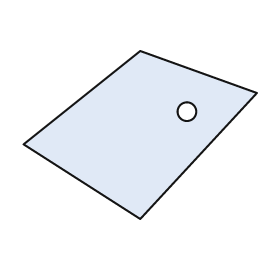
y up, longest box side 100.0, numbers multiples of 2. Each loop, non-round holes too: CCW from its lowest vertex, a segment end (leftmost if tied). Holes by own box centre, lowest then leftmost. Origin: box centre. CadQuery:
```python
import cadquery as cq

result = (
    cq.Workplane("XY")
    .moveTo(0.0, -36.0)
    .lineTo(50.0, 18.0)
    .lineTo(0.0, 36.0)
    .lineTo(-50.0, -4.0)
    .close()
    .moveTo(20.0, 10.0)
    .circle(4.0)
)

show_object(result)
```